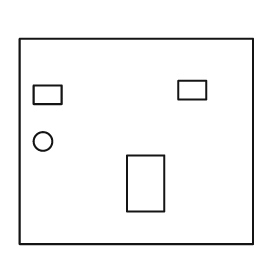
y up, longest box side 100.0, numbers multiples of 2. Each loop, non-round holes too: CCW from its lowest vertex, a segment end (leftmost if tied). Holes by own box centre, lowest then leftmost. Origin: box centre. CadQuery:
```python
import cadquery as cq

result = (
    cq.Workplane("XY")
    .moveTo(-50.0, -44.0)
    .lineTo(50.0, -44.0)
    .lineTo(50.0, 44.0)
    .lineTo(-50.0, 44.0)
    .close()
    .moveTo(-4.0, -30.0)
    .lineTo(12.0, -30.0)
    .lineTo(12.0, -6.0)
    .lineTo(-4.0, -6.0)
    .close()
    .moveTo(-40.0, 0.0)
    .circle(4.0)
    .moveTo(-44.0, 16.0)
    .lineTo(-32.0, 16.0)
    .lineTo(-32.0, 24.0)
    .lineTo(-44.0, 24.0)
    .close()
    .moveTo(18.0, 18.0)
    .lineTo(30.0, 18.0)
    .lineTo(30.0, 26.0)
    .lineTo(18.0, 26.0)
    .close()
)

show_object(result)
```